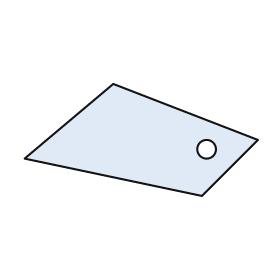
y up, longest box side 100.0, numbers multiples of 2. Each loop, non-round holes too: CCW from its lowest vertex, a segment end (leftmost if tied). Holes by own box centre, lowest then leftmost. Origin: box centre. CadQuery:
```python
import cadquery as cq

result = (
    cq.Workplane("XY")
    .moveTo(26.0, -24.0)
    .lineTo(50.0, 0.0)
    .lineTo(-12.0, 24.0)
    .lineTo(-50.0, -8.0)
    .close()
    .moveTo(28.0, -4.0)
    .circle(4.0)
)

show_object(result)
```